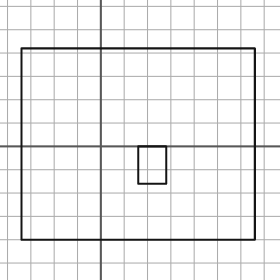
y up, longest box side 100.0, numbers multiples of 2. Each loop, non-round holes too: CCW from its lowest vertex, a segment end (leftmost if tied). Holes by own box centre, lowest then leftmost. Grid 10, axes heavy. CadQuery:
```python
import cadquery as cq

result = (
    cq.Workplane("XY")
    .moveTo(-34.0, -40.0)
    .lineTo(66.0, -40.0)
    .lineTo(66.0, 42.0)
    .lineTo(-34.0, 42.0)
    .close()
    .moveTo(16.0, -16.0)
    .lineTo(28.0, -16.0)
    .lineTo(28.0, 0.0)
    .lineTo(16.0, 0.0)
    .close()
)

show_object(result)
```